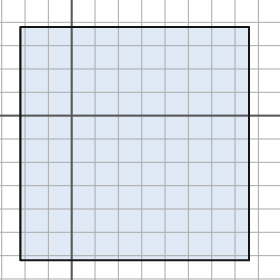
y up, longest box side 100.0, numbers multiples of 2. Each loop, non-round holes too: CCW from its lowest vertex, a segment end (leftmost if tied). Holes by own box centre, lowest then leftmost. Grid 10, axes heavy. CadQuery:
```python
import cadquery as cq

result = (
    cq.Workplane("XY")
    .moveTo(-22.0, -62.0)
    .lineTo(76.0, -62.0)
    .lineTo(76.0, 38.0)
    .lineTo(-22.0, 38.0)
    .close()
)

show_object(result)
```